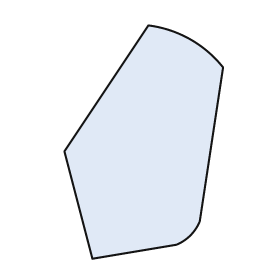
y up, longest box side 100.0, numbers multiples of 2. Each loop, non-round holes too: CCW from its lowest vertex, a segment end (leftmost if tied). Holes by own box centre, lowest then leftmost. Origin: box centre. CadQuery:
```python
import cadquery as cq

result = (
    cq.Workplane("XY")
    .moveTo(-22.0, -50.0)
    .lineTo(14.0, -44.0)
    .threePointArc((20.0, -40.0), (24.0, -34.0))
    .lineTo(34.0, 32.0)
    .threePointArc((20.0, 44.0), (2.0, 50.0))
    .lineTo(-34.0, -4.0)
    .close()
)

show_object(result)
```